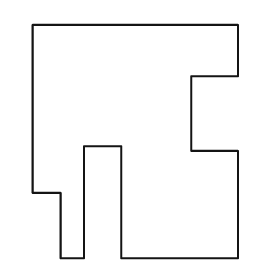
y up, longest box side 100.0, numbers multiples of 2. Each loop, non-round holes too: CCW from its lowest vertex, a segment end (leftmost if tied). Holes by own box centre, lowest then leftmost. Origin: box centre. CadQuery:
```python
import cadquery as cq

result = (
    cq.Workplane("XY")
    .moveTo(-32.0, -50.0)
    .lineTo(-22.0, -50.0)
    .lineTo(-22.0, -2.0)
    .lineTo(-6.0, -2.0)
    .lineTo(-6.0, -50.0)
    .lineTo(44.0, -50.0)
    .lineTo(44.0, -4.0)
    .lineTo(24.0, -4.0)
    .lineTo(24.0, 28.0)
    .lineTo(44.0, 28.0)
    .lineTo(44.0, 50.0)
    .lineTo(-44.0, 50.0)
    .lineTo(-44.0, -22.0)
    .lineTo(-32.0, -22.0)
    .close()
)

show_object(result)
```